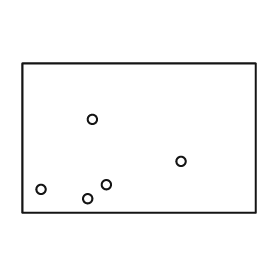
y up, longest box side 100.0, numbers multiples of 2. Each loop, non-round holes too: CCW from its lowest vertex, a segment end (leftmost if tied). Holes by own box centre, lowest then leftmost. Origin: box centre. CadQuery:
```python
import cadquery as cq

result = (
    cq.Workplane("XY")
    .moveTo(-50.0, -32.0)
    .lineTo(50.0, -32.0)
    .lineTo(50.0, 32.0)
    .lineTo(-50.0, 32.0)
    .close()
    .moveTo(-22.0, -26.0)
    .circle(2.0)
    .moveTo(-42.0, -22.0)
    .circle(2.0)
    .moveTo(-14.0, -20.0)
    .circle(2.0)
    .moveTo(18.0, -10.0)
    .circle(2.0)
    .moveTo(-20.0, 8.0)
    .circle(2.0)
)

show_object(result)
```